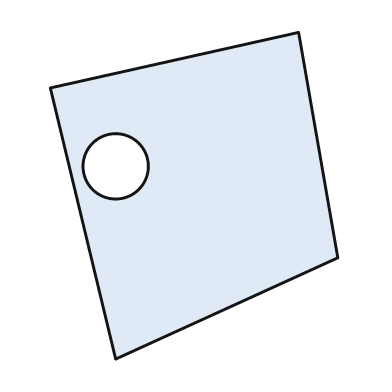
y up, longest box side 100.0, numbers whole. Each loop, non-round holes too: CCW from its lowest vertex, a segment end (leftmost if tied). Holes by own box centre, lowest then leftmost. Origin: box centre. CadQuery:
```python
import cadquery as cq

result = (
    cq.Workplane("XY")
    .moveTo(-24.0, -50.0)
    .lineTo(44.0, -19.0)
    .lineTo(32.0, 50.0)
    .lineTo(-44.0, 33.0)
    .close()
    .moveTo(-24.0, 9.0)
    .circle(10.0)
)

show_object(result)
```